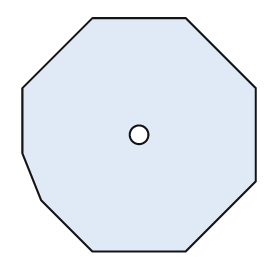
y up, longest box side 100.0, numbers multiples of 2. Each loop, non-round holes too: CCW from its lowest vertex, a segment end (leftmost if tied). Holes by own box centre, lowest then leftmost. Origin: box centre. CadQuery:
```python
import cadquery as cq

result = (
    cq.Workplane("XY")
    .moveTo(-20.0, -50.0)
    .lineTo(20.0, -50.0)
    .lineTo(50.0, -20.0)
    .lineTo(50.0, 20.0)
    .lineTo(20.0, 50.0)
    .lineTo(-20.0, 50.0)
    .lineTo(-50.0, 20.0)
    .lineTo(-50.0, -8.0)
    .lineTo(-42.0, -28.0)
    .close()
    .moveTo(0.0, 0.0)
    .circle(4.0)
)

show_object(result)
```